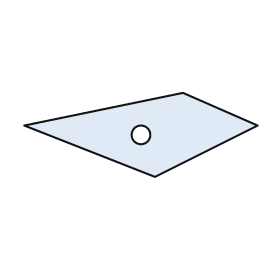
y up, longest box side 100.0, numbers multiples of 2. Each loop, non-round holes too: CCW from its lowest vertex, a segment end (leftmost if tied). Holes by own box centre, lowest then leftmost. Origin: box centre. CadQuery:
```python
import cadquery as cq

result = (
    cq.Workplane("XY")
    .moveTo(6.0, -18.0)
    .lineTo(50.0, 4.0)
    .lineTo(18.0, 18.0)
    .lineTo(-50.0, 4.0)
    .close()
    .moveTo(0.0, 0.0)
    .circle(4.0)
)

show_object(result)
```